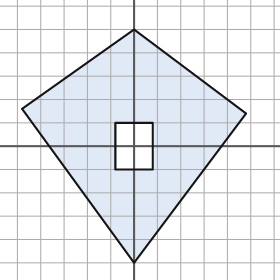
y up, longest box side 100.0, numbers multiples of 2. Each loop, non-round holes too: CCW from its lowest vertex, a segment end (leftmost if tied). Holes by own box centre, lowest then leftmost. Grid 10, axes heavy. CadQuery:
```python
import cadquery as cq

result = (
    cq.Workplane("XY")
    .moveTo(0.0, -50.0)
    .lineTo(48.0, 14.0)
    .lineTo(0.0, 50.0)
    .lineTo(-48.0, 16.0)
    .close()
    .moveTo(-8.0, -10.0)
    .lineTo(8.0, -10.0)
    .lineTo(8.0, 10.0)
    .lineTo(-8.0, 10.0)
    .close()
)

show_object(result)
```